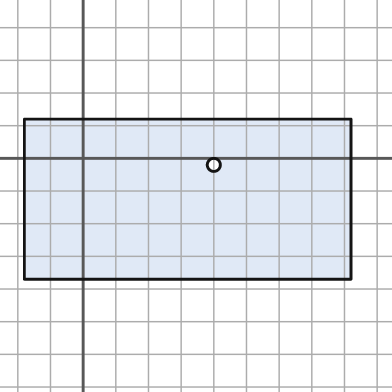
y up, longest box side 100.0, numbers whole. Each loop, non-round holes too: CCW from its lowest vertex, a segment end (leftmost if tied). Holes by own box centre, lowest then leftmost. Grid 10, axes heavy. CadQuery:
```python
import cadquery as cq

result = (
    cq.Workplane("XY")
    .moveTo(-18.0, -37.0)
    .lineTo(82.0, -37.0)
    .lineTo(82.0, 12.0)
    .lineTo(-18.0, 12.0)
    .close()
    .moveTo(40.0, -2.0)
    .circle(2.0)
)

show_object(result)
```